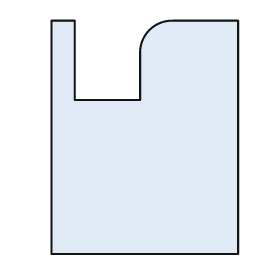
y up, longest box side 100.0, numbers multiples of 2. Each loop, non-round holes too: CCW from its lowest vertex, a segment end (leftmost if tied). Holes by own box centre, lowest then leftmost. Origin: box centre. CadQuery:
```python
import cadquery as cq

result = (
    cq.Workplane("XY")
    .moveTo(-40.0, -50.0)
    .lineTo(40.0, -50.0)
    .lineTo(40.0, 50.0)
    .lineTo(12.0, 50.0)
    .threePointArc((2.0, 46.0), (-2.0, 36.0))
    .lineTo(-2.0, 16.0)
    .lineTo(-30.0, 16.0)
    .lineTo(-30.0, 50.0)
    .lineTo(-40.0, 50.0)
    .close()
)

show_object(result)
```